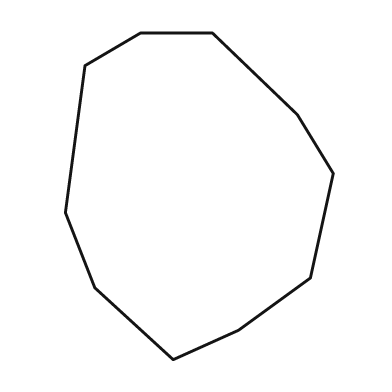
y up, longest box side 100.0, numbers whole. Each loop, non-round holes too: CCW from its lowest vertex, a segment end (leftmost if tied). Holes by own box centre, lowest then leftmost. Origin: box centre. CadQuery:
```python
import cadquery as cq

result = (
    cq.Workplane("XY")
    .moveTo(-8.0, -50.0)
    .lineTo(12.0, -41.0)
    .lineTo(34.0, -25.0)
    .lineTo(41.0, 7.0)
    .lineTo(30.0, 25.0)
    .lineTo(4.0, 50.0)
    .lineTo(-18.0, 50.0)
    .lineTo(-35.0, 40.0)
    .lineTo(-41.0, -5.0)
    .lineTo(-32.0, -28.0)
    .close()
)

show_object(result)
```